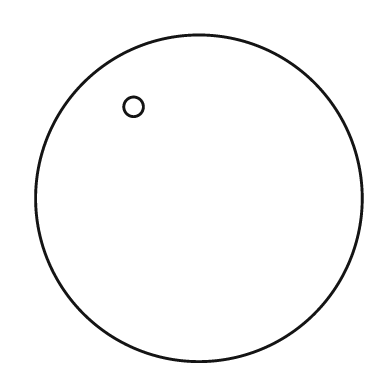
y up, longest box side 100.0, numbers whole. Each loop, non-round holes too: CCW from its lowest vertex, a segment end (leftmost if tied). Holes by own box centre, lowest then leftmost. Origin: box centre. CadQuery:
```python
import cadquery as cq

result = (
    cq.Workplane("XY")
    .moveTo(0.0, 0.0)
    .circle(50.0)
    .moveTo(-20.0, 28.0)
    .circle(3.0)
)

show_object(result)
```